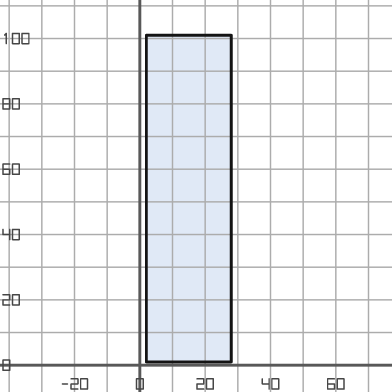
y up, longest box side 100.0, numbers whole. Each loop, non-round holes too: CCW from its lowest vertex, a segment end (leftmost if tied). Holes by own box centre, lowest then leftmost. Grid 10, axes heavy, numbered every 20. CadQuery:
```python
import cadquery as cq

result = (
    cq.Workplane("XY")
    .moveTo(2.0, 1.0)
    .lineTo(28.0, 1.0)
    .lineTo(28.0, 101.0)
    .lineTo(2.0, 101.0)
    .close()
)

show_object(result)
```